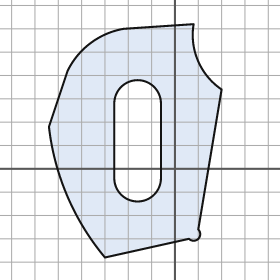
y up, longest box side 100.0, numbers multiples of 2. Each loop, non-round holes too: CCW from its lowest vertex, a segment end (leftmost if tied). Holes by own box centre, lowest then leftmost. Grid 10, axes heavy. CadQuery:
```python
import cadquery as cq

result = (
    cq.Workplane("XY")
    .moveTo(-30.0, -38.0)
    .lineTo(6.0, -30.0)
    .threePointArc((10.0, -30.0), (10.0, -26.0))
    .lineTo(20.0, 34.0)
    .threePointArc((10.0, 46.0), (8.0, 62.0))
    .lineTo(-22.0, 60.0)
    .threePointArc((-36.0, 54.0), (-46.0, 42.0))
    .lineTo(-54.0, 18.0)
    .threePointArc((-46.0, -12.0), (-30.0, -38.0))
    .close()
    .moveTo(-26.0, -4.0)
    .threePointArc((-16.0, -14.0), (-6.0, -4.0))
    .lineTo(-6.0, 28.0)
    .threePointArc((-16.0, 38.0), (-26.0, 28.0))
    .close()
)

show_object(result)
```